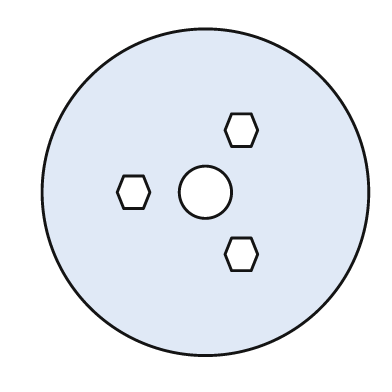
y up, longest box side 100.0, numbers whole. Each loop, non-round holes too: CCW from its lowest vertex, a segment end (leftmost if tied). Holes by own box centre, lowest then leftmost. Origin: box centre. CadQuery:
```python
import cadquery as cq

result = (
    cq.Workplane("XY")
    .moveTo(0.0, 0.0)
    .circle(50.0)
    .moveTo(8.0, -24.0)
    .lineTo(14.0, -24.0)
    .lineTo(16.0, -19.0)
    .lineTo(14.0, -14.0)
    .lineTo(8.0, -14.0)
    .lineTo(6.0, -19.0)
    .close()
    .moveTo(-25.0, -5.0)
    .lineTo(-19.0, -5.0)
    .lineTo(-17.0, 0.0)
    .lineTo(-19.0, 5.0)
    .lineTo(-25.0, 5.0)
    .lineTo(-27.0, 0.0)
    .close()
    .moveTo(0.0, 0.0)
    .circle(8.0)
    .moveTo(8.0, 14.0)
    .lineTo(14.0, 14.0)
    .lineTo(16.0, 19.0)
    .lineTo(14.0, 24.0)
    .lineTo(8.0, 24.0)
    .lineTo(6.0, 19.0)
    .close()
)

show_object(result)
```